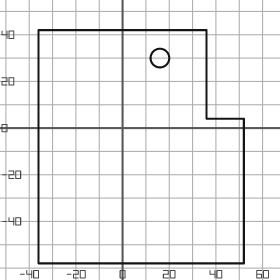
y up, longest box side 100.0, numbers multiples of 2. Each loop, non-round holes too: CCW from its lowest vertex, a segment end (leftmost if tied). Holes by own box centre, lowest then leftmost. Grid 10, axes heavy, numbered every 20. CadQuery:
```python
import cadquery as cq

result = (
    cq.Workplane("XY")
    .moveTo(-36.0, -58.0)
    .lineTo(52.0, -58.0)
    .lineTo(52.0, 4.0)
    .lineTo(36.0, 4.0)
    .lineTo(36.0, 42.0)
    .lineTo(-36.0, 42.0)
    .close()
    .moveTo(16.0, 30.0)
    .circle(4.0)
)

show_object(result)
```